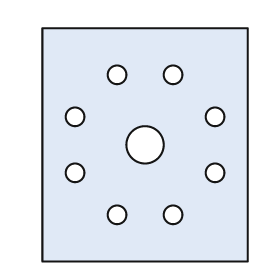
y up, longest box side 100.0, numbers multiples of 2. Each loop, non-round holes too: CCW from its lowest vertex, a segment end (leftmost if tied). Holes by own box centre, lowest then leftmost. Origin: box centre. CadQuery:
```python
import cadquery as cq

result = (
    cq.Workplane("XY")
    .moveTo(-44.0, -50.0)
    .lineTo(44.0, -50.0)
    .lineTo(44.0, 50.0)
    .lineTo(-44.0, 50.0)
    .close()
    .moveTo(-12.0, -30.0)
    .circle(4.0)
    .moveTo(12.0, -30.0)
    .circle(4.0)
    .moveTo(-30.0, -12.0)
    .circle(4.0)
    .moveTo(30.0, -12.0)
    .circle(4.0)
    .moveTo(0.0, 0.0)
    .circle(8.0)
    .moveTo(-30.0, 12.0)
    .circle(4.0)
    .moveTo(30.0, 12.0)
    .circle(4.0)
    .moveTo(-12.0, 30.0)
    .circle(4.0)
    .moveTo(12.0, 30.0)
    .circle(4.0)
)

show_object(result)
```